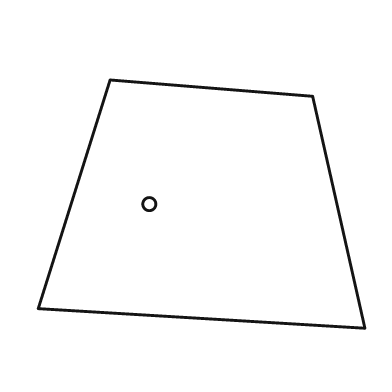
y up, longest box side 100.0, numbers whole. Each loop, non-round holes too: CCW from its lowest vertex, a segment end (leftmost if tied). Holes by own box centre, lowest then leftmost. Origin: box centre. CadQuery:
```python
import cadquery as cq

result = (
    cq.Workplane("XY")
    .moveTo(50.0, -38.0)
    .lineTo(34.0, 33.0)
    .lineTo(-28.0, 38.0)
    .lineTo(-50.0, -32.0)
    .close()
    .moveTo(-16.0, 0.0)
    .circle(2.0)
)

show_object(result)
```